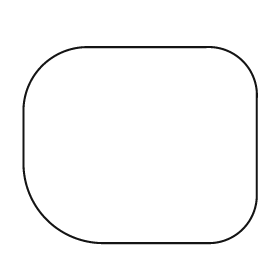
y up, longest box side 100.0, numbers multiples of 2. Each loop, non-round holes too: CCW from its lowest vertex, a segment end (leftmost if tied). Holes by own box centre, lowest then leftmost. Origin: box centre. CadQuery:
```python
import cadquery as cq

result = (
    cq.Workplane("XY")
    .moveTo(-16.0, -42.0)
    .lineTo(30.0, -42.0)
    .threePointArc((44.0, -36.0), (50.0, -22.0))
    .lineTo(50.0, 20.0)
    .threePointArc((44.0, 36.0), (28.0, 42.0))
    .lineTo(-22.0, 42.0)
    .threePointArc((-42.0, 34.0), (-50.0, 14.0))
    .lineTo(-50.0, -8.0)
    .threePointArc((-40.0, -32.0), (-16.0, -42.0))
    .close()
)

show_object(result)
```